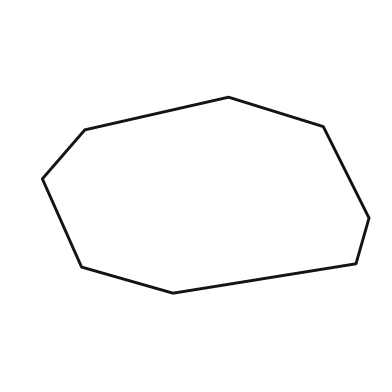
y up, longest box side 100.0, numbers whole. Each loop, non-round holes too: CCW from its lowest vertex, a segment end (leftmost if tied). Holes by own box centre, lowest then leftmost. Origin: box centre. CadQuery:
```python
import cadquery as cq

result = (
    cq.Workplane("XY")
    .moveTo(-10.0, -30.0)
    .lineTo(46.0, -21.0)
    .lineTo(50.0, -7.0)
    .lineTo(36.0, 21.0)
    .lineTo(7.0, 30.0)
    .lineTo(-37.0, 20.0)
    .lineTo(-50.0, 5.0)
    .lineTo(-38.0, -22.0)
    .close()
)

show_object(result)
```